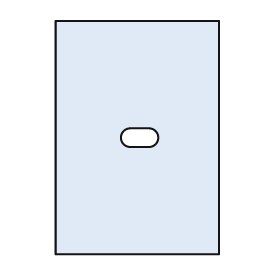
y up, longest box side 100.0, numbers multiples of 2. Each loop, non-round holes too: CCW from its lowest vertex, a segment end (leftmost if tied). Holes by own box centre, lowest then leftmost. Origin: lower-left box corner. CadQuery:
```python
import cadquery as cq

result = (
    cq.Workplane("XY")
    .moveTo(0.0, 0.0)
    .lineTo(70.0, 0.0)
    .lineTo(70.0, 100.0)
    .lineTo(0.0, 100.0)
    .close()
    .moveTo(32.0, 46.0)
    .lineTo(40.0, 46.0)
    .threePointArc((44.0, 50.0), (40.0, 54.0))
    .lineTo(32.0, 54.0)
    .threePointArc((28.0, 50.0), (32.0, 46.0))
    .close()
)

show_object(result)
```